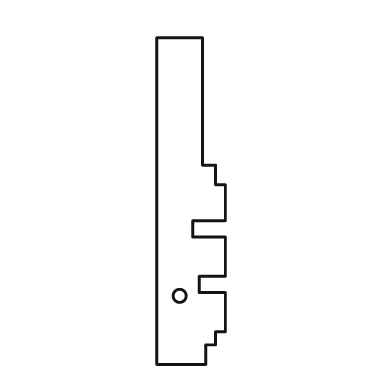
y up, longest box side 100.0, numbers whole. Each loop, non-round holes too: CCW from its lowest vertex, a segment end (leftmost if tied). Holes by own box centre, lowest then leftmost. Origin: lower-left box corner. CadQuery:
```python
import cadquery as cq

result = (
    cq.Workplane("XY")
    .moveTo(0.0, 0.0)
    .lineTo(15.0, 0.0)
    .lineTo(15.0, 6.0)
    .lineTo(18.0, 6.0)
    .lineTo(18.0, 10.0)
    .lineTo(21.0, 10.0)
    .lineTo(21.0, 22.0)
    .lineTo(13.0, 22.0)
    .lineTo(13.0, 27.0)
    .lineTo(21.0, 27.0)
    .lineTo(21.0, 39.0)
    .lineTo(11.0, 39.0)
    .lineTo(11.0, 44.0)
    .lineTo(21.0, 44.0)
    .lineTo(21.0, 55.0)
    .lineTo(18.0, 55.0)
    .lineTo(18.0, 61.0)
    .lineTo(14.0, 61.0)
    .lineTo(14.0, 100.0)
    .lineTo(0.0, 100.0)
    .close()
    .moveTo(7.0, 21.0)
    .circle(2.0)
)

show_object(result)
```